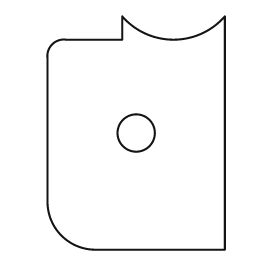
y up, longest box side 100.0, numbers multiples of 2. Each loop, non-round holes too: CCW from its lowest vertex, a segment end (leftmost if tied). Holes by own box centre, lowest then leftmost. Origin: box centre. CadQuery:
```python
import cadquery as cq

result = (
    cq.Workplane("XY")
    .moveTo(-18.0, -50.0)
    .lineTo(38.0, -50.0)
    .lineTo(38.0, 50.0)
    .threePointArc((16.0, 40.0), (-6.0, 50.0))
    .lineTo(-6.0, 40.0)
    .lineTo(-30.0, 40.0)
    .threePointArc((-36.0, 38.0), (-38.0, 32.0))
    .lineTo(-38.0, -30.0)
    .threePointArc((-32.0, -44.0), (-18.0, -50.0))
    .close()
    .moveTo(0.0, 0.0)
    .circle(8.0)
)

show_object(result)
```